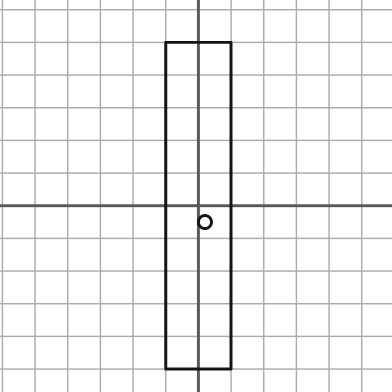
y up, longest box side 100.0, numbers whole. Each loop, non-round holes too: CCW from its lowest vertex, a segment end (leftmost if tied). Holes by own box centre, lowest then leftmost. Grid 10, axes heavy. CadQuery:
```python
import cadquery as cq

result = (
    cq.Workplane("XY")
    .moveTo(-10.0, -50.0)
    .lineTo(10.0, -50.0)
    .lineTo(10.0, 50.0)
    .lineTo(-10.0, 50.0)
    .close()
    .moveTo(2.0, -5.0)
    .circle(2.0)
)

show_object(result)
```